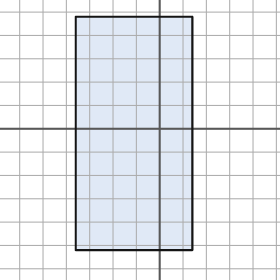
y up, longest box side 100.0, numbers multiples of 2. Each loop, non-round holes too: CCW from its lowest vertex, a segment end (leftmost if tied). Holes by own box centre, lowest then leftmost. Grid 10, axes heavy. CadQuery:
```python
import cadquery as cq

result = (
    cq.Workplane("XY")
    .moveTo(-36.0, -52.0)
    .lineTo(14.0, -52.0)
    .lineTo(14.0, 48.0)
    .lineTo(-36.0, 48.0)
    .close()
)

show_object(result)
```